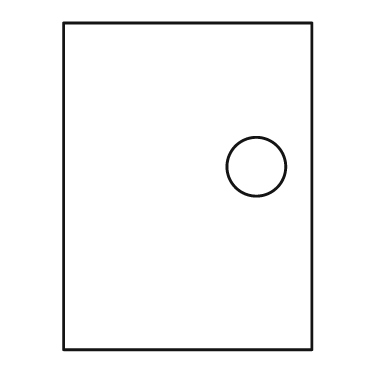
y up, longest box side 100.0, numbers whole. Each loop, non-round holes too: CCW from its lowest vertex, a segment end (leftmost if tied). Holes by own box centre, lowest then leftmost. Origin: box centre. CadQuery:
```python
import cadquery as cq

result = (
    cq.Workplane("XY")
    .moveTo(-38.0, -50.0)
    .lineTo(38.0, -50.0)
    .lineTo(38.0, 50.0)
    .lineTo(-38.0, 50.0)
    .close()
    .moveTo(21.0, 6.0)
    .circle(9.0)
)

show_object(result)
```